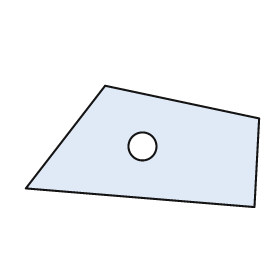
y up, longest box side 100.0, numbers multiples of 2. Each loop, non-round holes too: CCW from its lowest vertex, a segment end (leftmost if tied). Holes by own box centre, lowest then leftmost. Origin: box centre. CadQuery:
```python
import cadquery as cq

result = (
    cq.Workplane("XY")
    .moveTo(48.0, -26.0)
    .lineTo(50.0, 12.0)
    .lineTo(-16.0, 26.0)
    .lineTo(-50.0, -18.0)
    .close()
    .moveTo(0.0, 0.0)
    .circle(6.0)
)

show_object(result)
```